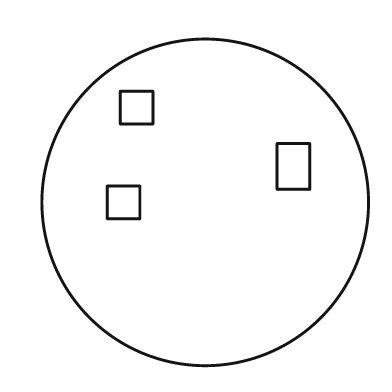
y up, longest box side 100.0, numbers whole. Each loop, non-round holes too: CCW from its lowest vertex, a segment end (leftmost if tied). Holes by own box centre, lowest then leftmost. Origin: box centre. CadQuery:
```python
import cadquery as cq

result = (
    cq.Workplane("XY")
    .moveTo(0.0, 0.0)
    .circle(50.0)
    .moveTo(-30.0, -5.0)
    .lineTo(-20.0, -5.0)
    .lineTo(-20.0, 5.0)
    .lineTo(-30.0, 5.0)
    .close()
    .moveTo(22.0, 4.0)
    .lineTo(32.0, 4.0)
    .lineTo(32.0, 18.0)
    .lineTo(22.0, 18.0)
    .close()
    .moveTo(-26.0, 24.0)
    .lineTo(-16.0, 24.0)
    .lineTo(-16.0, 34.0)
    .lineTo(-26.0, 34.0)
    .close()
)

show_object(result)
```